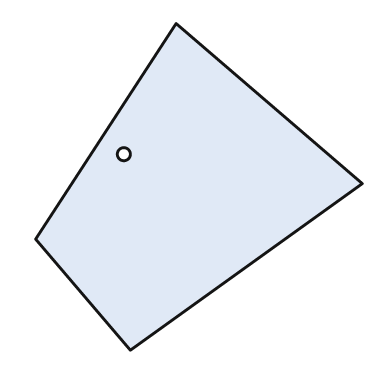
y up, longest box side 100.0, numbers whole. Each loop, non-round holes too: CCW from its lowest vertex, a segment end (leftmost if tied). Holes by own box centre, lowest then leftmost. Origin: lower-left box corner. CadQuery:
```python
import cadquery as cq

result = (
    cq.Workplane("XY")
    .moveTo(29.0, 0.0)
    .lineTo(100.0, 51.0)
    .lineTo(43.0, 100.0)
    .lineTo(0.0, 34.0)
    .close()
    .moveTo(27.0, 60.0)
    .circle(2.0)
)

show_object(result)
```